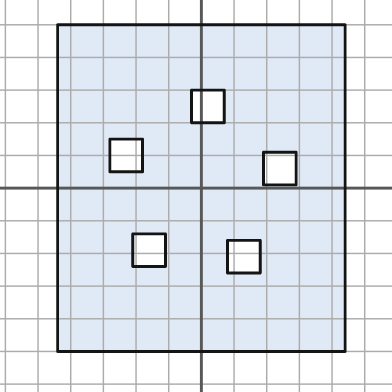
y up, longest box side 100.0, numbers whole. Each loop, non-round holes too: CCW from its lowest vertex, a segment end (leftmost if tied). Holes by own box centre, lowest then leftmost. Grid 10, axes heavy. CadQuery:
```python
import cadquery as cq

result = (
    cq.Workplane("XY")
    .moveTo(-44.0, -50.0)
    .lineTo(44.0, -50.0)
    .lineTo(44.0, 50.0)
    .lineTo(-44.0, 50.0)
    .close()
    .moveTo(8.0, -26.0)
    .lineTo(18.0, -26.0)
    .lineTo(18.0, -16.0)
    .lineTo(8.0, -16.0)
    .close()
    .moveTo(-21.0, -24.0)
    .lineTo(-11.0, -24.0)
    .lineTo(-11.0, -14.0)
    .lineTo(-21.0, -14.0)
    .close()
    .moveTo(19.0, 1.0)
    .lineTo(29.0, 1.0)
    .lineTo(29.0, 11.0)
    .lineTo(19.0, 11.0)
    .close()
    .moveTo(-28.0, 5.0)
    .lineTo(-18.0, 5.0)
    .lineTo(-18.0, 15.0)
    .lineTo(-28.0, 15.0)
    .close()
    .moveTo(-3.0, 20.0)
    .lineTo(7.0, 20.0)
    .lineTo(7.0, 30.0)
    .lineTo(-3.0, 30.0)
    .close()
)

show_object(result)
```